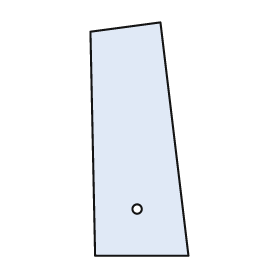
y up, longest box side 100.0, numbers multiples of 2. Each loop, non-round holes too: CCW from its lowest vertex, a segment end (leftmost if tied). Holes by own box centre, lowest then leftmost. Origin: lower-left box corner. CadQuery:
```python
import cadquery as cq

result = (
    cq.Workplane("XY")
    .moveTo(2.0, 0.0)
    .lineTo(42.0, 0.0)
    .lineTo(30.0, 100.0)
    .lineTo(0.0, 96.0)
    .close()
    .moveTo(20.0, 20.0)
    .circle(2.0)
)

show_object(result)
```